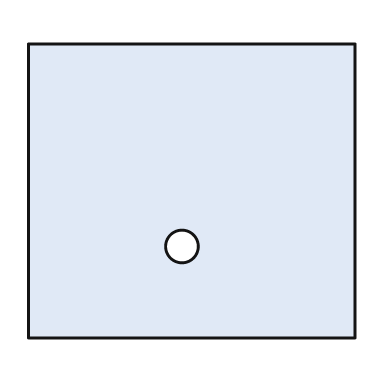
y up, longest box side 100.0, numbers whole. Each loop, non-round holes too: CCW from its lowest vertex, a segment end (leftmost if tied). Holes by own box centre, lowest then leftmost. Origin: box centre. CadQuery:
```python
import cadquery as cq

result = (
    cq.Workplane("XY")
    .moveTo(-50.0, -45.0)
    .lineTo(50.0, -45.0)
    .lineTo(50.0, 45.0)
    .lineTo(-50.0, 45.0)
    .close()
    .moveTo(-3.0, -17.0)
    .circle(5.0)
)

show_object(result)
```